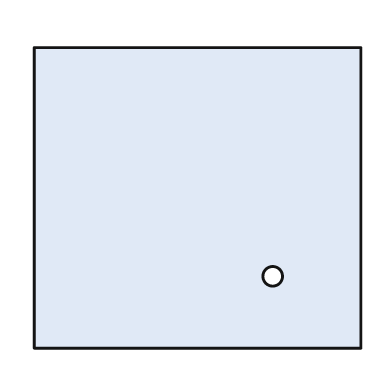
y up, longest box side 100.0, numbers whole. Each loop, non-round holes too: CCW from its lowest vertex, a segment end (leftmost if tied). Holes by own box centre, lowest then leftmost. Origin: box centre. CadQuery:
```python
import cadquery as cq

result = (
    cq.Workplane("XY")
    .moveTo(-50.0, -46.0)
    .lineTo(50.0, -46.0)
    .lineTo(50.0, 46.0)
    .lineTo(-50.0, 46.0)
    .close()
    .moveTo(23.0, -24.0)
    .circle(3.0)
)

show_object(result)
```